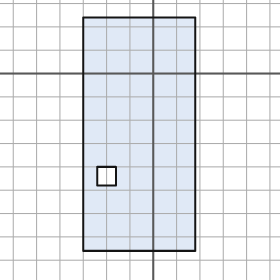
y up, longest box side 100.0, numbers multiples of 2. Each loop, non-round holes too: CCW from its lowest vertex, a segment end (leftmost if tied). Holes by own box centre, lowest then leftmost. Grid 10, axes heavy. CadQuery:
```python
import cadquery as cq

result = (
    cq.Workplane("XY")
    .moveTo(-30.0, -76.0)
    .lineTo(18.0, -76.0)
    .lineTo(18.0, 24.0)
    .lineTo(-30.0, 24.0)
    .close()
    .moveTo(-24.0, -48.0)
    .lineTo(-16.0, -48.0)
    .lineTo(-16.0, -40.0)
    .lineTo(-24.0, -40.0)
    .close()
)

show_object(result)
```